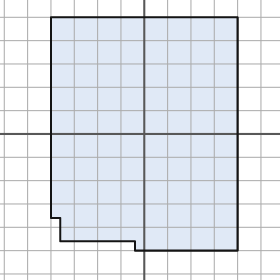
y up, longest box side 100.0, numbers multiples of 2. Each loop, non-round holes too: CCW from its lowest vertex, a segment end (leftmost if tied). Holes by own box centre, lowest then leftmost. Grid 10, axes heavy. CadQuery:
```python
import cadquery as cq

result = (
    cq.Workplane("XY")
    .moveTo(-4.0, -50.0)
    .lineTo(40.0, -50.0)
    .lineTo(40.0, 50.0)
    .lineTo(-40.0, 50.0)
    .lineTo(-40.0, -36.0)
    .lineTo(-36.0, -36.0)
    .lineTo(-36.0, -46.0)
    .lineTo(-4.0, -46.0)
    .close()
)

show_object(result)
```